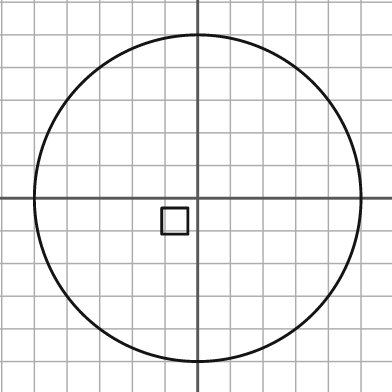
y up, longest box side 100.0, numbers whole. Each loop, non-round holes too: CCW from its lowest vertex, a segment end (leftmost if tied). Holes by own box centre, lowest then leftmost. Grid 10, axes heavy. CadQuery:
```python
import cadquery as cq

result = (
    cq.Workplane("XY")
    .moveTo(0.0, 0.0)
    .circle(50.0)
    .moveTo(-11.0, -11.0)
    .lineTo(-3.0, -11.0)
    .lineTo(-3.0, -3.0)
    .lineTo(-11.0, -3.0)
    .close()
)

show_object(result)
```